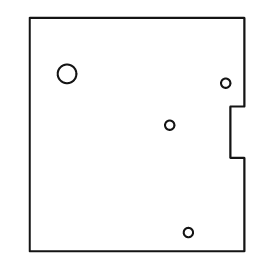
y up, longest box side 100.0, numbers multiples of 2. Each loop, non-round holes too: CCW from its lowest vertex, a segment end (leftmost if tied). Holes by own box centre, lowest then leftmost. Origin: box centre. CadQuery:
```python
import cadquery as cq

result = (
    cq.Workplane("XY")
    .moveTo(-46.0, -50.0)
    .lineTo(46.0, -50.0)
    .lineTo(46.0, -10.0)
    .lineTo(40.0, -10.0)
    .lineTo(40.0, 12.0)
    .lineTo(46.0, 12.0)
    .lineTo(46.0, 50.0)
    .lineTo(-46.0, 50.0)
    .close()
    .moveTo(22.0, -42.0)
    .circle(2.0)
    .moveTo(14.0, 4.0)
    .circle(2.0)
    .moveTo(38.0, 22.0)
    .circle(2.0)
    .moveTo(-30.0, 26.0)
    .circle(4.0)
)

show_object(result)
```